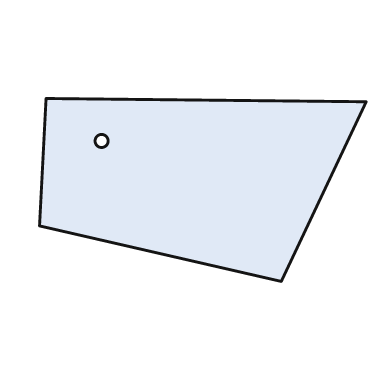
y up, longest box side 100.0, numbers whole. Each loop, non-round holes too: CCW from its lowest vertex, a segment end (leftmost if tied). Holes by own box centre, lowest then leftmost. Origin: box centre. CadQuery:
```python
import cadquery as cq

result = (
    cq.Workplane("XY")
    .moveTo(24.0, -28.0)
    .lineTo(50.0, 27.0)
    .lineTo(-48.0, 28.0)
    .lineTo(-50.0, -11.0)
    .close()
    .moveTo(-31.0, 15.0)
    .circle(2.0)
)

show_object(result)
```